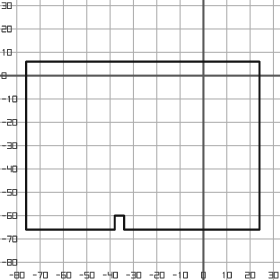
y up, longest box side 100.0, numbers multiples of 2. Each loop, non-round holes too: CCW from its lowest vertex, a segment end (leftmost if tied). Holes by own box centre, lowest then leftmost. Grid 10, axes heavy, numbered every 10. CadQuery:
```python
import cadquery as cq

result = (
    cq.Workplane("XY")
    .moveTo(-76.0, -66.0)
    .lineTo(-38.0, -66.0)
    .lineTo(-38.0, -60.0)
    .lineTo(-34.0, -60.0)
    .lineTo(-34.0, -66.0)
    .lineTo(24.0, -66.0)
    .lineTo(24.0, 6.0)
    .lineTo(-76.0, 6.0)
    .close()
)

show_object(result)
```